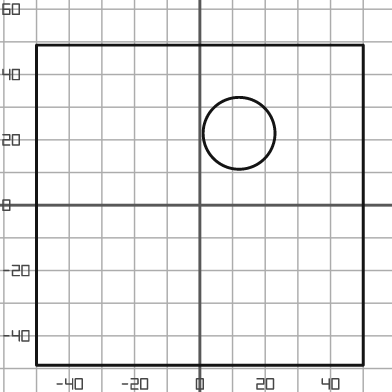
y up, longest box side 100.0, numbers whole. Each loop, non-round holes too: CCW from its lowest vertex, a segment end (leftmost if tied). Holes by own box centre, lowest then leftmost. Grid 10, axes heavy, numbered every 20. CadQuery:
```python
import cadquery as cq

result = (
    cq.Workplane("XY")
    .moveTo(-50.0, -49.0)
    .lineTo(50.0, -49.0)
    .lineTo(50.0, 49.0)
    .lineTo(-50.0, 49.0)
    .close()
    .moveTo(12.0, 22.0)
    .circle(11.0)
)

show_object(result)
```